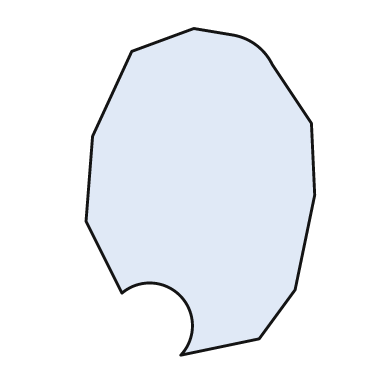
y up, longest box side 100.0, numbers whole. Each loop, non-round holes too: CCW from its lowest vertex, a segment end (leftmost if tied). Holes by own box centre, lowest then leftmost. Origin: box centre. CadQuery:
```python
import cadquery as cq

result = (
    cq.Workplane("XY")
    .moveTo(-6.0, -50.0)
    .lineTo(18.0, -45.0)
    .lineTo(29.0, -30.0)
    .lineTo(35.0, -1.0)
    .lineTo(34.0, 21.0)
    .lineTo(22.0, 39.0)
    .threePointArc((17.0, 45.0), (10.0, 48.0))
    .lineTo(-2.0, 50.0)
    .lineTo(-21.0, 43.0)
    .lineTo(-33.0, 17.0)
    .lineTo(-35.0, -9.0)
    .lineTo(-24.0, -31.0)
    .threePointArc((-6.0, -32.0), (-6.0, -50.0))
    .close()
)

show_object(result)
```